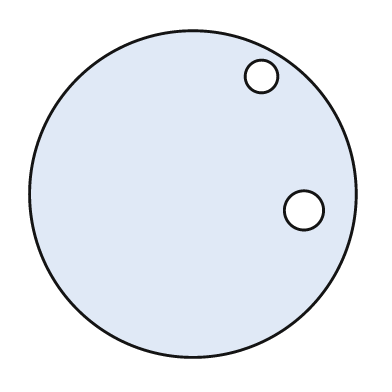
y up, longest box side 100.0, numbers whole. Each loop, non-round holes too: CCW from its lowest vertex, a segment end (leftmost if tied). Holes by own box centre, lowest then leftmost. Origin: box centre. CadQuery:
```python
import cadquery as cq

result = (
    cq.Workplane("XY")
    .moveTo(0.0, 0.0)
    .circle(50.0)
    .moveTo(34.0, -5.0)
    .circle(6.0)
    .moveTo(21.0, 36.0)
    .circle(5.0)
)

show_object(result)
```